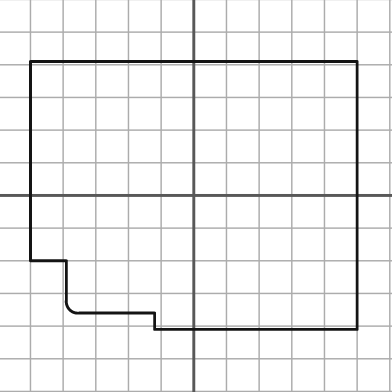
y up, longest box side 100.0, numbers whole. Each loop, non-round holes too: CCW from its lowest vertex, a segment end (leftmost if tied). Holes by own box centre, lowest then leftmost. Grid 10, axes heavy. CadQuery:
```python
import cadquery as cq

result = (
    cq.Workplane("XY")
    .moveTo(-12.0, -41.0)
    .lineTo(50.0, -41.0)
    .lineTo(50.0, 41.0)
    .lineTo(-50.0, 41.0)
    .lineTo(-50.0, -20.0)
    .lineTo(-39.0, -20.0)
    .lineTo(-39.0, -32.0)
    .threePointArc((-38.0, -35.0), (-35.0, -36.0))
    .lineTo(-12.0, -36.0)
    .close()
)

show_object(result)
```